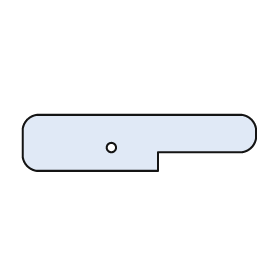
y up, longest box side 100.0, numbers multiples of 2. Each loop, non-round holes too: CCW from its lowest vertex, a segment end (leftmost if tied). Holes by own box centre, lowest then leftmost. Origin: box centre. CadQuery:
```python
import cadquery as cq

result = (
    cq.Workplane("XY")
    .moveTo(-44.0, -12.0)
    .lineTo(8.0, -12.0)
    .lineTo(8.0, -4.0)
    .lineTo(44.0, -4.0)
    .threePointArc((48.0, -2.0), (50.0, 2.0))
    .lineTo(50.0, 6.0)
    .threePointArc((48.0, 10.0), (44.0, 12.0))
    .lineTo(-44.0, 12.0)
    .threePointArc((-48.0, 10.0), (-50.0, 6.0))
    .lineTo(-50.0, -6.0)
    .threePointArc((-48.0, -10.0), (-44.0, -12.0))
    .close()
    .moveTo(-12.0, -2.0)
    .circle(2.0)
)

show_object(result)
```